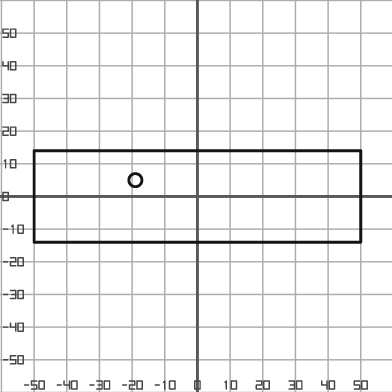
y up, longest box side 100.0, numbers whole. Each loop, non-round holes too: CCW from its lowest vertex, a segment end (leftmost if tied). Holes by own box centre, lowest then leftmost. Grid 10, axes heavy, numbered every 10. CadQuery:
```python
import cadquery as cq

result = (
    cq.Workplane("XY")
    .moveTo(-50.0, -14.0)
    .lineTo(50.0, -14.0)
    .lineTo(50.0, 14.0)
    .lineTo(-50.0, 14.0)
    .close()
    .moveTo(-19.0, 5.0)
    .circle(2.0)
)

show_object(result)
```